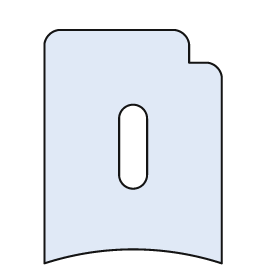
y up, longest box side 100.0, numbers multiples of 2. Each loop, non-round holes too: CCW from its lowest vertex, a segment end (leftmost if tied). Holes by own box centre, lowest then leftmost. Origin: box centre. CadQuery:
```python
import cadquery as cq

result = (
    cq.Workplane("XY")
    .moveTo(-38.0, -50.0)
    .threePointArc((0.0, -44.0), (38.0, -50.0))
    .lineTo(38.0, 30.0)
    .threePointArc((36.0, 34.0), (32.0, 36.0))
    .lineTo(24.0, 36.0)
    .lineTo(24.0, 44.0)
    .threePointArc((22.0, 48.0), (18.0, 50.0))
    .lineTo(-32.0, 50.0)
    .threePointArc((-36.0, 48.0), (-38.0, 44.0))
    .close()
    .moveTo(-6.0, -12.0)
    .threePointArc((0.0, -18.0), (6.0, -12.0))
    .lineTo(6.0, 12.0)
    .threePointArc((0.0, 18.0), (-6.0, 12.0))
    .close()
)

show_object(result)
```